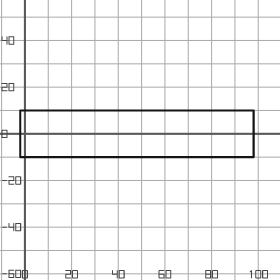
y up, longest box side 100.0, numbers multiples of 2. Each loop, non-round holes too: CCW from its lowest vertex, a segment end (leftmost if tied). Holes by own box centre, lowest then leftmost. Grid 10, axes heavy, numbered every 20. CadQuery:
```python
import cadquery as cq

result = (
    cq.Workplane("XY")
    .moveTo(-2.0, -10.0)
    .lineTo(98.0, -10.0)
    .lineTo(98.0, 10.0)
    .lineTo(-2.0, 10.0)
    .close()
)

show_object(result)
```